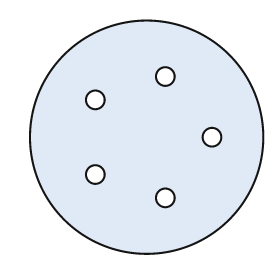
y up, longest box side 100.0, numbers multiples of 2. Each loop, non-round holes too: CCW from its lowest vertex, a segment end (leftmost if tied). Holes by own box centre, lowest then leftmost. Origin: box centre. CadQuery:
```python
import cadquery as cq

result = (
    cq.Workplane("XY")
    .moveTo(0.0, 0.0)
    .circle(50.0)
    .moveTo(8.0, -26.0)
    .circle(4.0)
    .moveTo(-22.0, -16.0)
    .circle(4.0)
    .moveTo(28.0, 0.0)
    .circle(4.0)
    .moveTo(-22.0, 16.0)
    .circle(4.0)
    .moveTo(8.0, 26.0)
    .circle(4.0)
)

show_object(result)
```